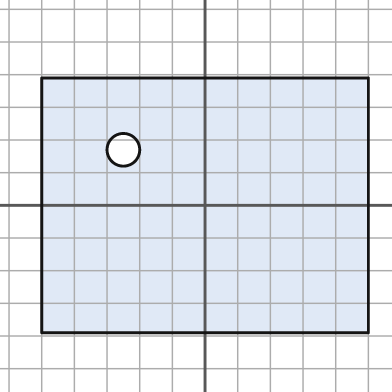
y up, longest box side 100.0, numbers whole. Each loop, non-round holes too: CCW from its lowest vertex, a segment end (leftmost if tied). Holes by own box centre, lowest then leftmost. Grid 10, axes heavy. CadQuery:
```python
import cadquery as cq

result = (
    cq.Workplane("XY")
    .moveTo(-50.0, -39.0)
    .lineTo(50.0, -39.0)
    .lineTo(50.0, 39.0)
    .lineTo(-50.0, 39.0)
    .close()
    .moveTo(-25.0, 17.0)
    .circle(5.0)
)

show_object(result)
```